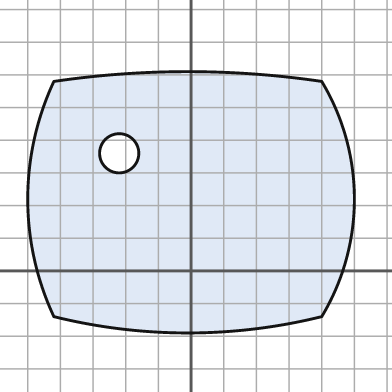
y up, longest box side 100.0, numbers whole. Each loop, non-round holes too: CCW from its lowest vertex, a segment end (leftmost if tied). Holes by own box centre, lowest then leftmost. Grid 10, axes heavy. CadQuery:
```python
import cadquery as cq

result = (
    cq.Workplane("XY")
    .moveTo(-42.0, -14.0)
    .threePointArc((-1.0, -19.0), (40.0, -14.0))
    .threePointArc((50.0, 22.0), (40.0, 58.0))
    .threePointArc((-1.0, 61.0), (-42.0, 58.0))
    .threePointArc((-50.0, 22.0), (-42.0, -14.0))
    .close()
    .moveTo(-22.0, 36.0)
    .circle(6.0)
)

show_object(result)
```